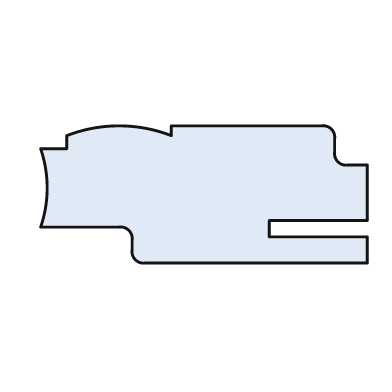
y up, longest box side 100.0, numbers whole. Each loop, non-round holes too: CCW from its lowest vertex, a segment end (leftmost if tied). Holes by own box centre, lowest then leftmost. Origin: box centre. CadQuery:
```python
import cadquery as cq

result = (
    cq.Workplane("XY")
    .moveTo(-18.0, -21.0)
    .lineTo(50.0, -21.0)
    .lineTo(50.0, -13.0)
    .lineTo(20.0, -13.0)
    .lineTo(20.0, -8.0)
    .lineTo(50.0, -8.0)
    .lineTo(50.0, 9.0)
    .lineTo(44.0, 9.0)
    .threePointArc((41.0, 10.0), (40.0, 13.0))
    .lineTo(40.0, 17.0)
    .threePointArc((39.0, 20.0), (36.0, 21.0))
    .lineTo(-10.0, 21.0)
    .lineTo(-10.0, 18.0)
    .threePointArc((-26.0, 21.0), (-42.0, 18.0))
    .lineTo(-42.0, 14.0)
    .lineTo(-50.0, 14.0)
    .threePointArc((-48.0, 2.0), (-50.0, -10.0))
    .lineTo(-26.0, -10.0)
    .threePointArc((-23.0, -11.0), (-22.0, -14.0))
    .lineTo(-22.0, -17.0)
    .threePointArc((-21.0, -20.0), (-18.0, -21.0))
    .close()
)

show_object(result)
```